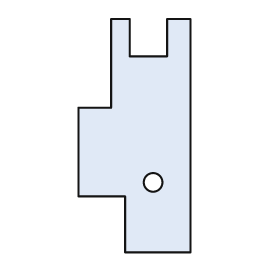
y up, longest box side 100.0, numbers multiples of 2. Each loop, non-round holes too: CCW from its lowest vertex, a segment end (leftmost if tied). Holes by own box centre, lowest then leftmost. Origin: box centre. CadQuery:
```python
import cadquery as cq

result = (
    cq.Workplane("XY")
    .moveTo(-4.0, -50.0)
    .lineTo(24.0, -50.0)
    .lineTo(24.0, 50.0)
    .lineTo(14.0, 50.0)
    .lineTo(14.0, 34.0)
    .lineTo(-2.0, 34.0)
    .lineTo(-2.0, 50.0)
    .lineTo(-10.0, 50.0)
    .lineTo(-10.0, 12.0)
    .lineTo(-24.0, 12.0)
    .lineTo(-24.0, -26.0)
    .lineTo(-4.0, -26.0)
    .close()
    .moveTo(8.0, -20.0)
    .circle(4.0)
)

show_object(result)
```